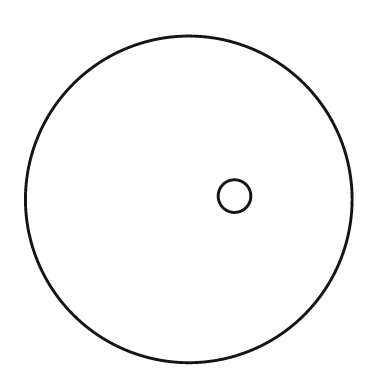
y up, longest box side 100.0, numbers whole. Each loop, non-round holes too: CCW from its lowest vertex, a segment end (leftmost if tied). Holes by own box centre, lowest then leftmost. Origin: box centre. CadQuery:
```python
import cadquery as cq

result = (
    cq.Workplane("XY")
    .moveTo(0.0, 0.0)
    .circle(50.0)
    .moveTo(14.0, 1.0)
    .circle(5.0)
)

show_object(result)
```